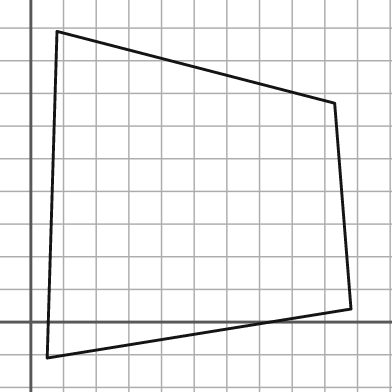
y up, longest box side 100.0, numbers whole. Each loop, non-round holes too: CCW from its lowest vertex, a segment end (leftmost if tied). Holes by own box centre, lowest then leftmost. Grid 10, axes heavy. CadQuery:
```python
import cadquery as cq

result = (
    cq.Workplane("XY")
    .moveTo(5.0, -11.0)
    .lineTo(98.0, 4.0)
    .lineTo(93.0, 67.0)
    .lineTo(8.0, 89.0)
    .close()
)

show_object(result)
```